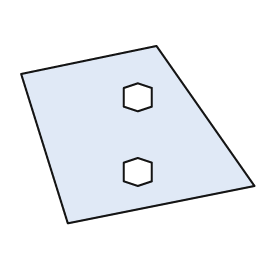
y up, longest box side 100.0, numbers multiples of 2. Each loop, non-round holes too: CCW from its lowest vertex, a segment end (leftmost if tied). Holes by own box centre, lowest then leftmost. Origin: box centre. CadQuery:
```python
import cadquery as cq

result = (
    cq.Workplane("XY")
    .moveTo(-30.0, -38.0)
    .lineTo(50.0, -22.0)
    .lineTo(8.0, 38.0)
    .lineTo(-50.0, 26.0)
    .close()
    .moveTo(0.0, -22.0)
    .lineTo(6.0, -20.0)
    .lineTo(6.0, -12.0)
    .lineTo(0.0, -10.0)
    .lineTo(-6.0, -12.0)
    .lineTo(-6.0, -20.0)
    .close()
    .moveTo(0.0, 10.0)
    .lineTo(6.0, 12.0)
    .lineTo(6.0, 20.0)
    .lineTo(0.0, 22.0)
    .lineTo(-6.0, 20.0)
    .lineTo(-6.0, 12.0)
    .close()
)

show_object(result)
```